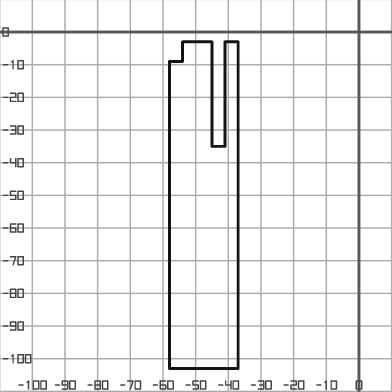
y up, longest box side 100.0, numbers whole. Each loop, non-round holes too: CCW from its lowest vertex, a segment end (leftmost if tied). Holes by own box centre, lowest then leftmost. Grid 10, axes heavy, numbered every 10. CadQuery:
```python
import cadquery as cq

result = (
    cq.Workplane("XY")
    .moveTo(-58.0, -103.0)
    .lineTo(-37.0, -103.0)
    .lineTo(-37.0, -3.0)
    .lineTo(-41.0, -3.0)
    .lineTo(-41.0, -35.0)
    .lineTo(-45.0, -35.0)
    .lineTo(-45.0, -3.0)
    .lineTo(-54.0, -3.0)
    .lineTo(-54.0, -9.0)
    .lineTo(-58.0, -9.0)
    .close()
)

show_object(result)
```